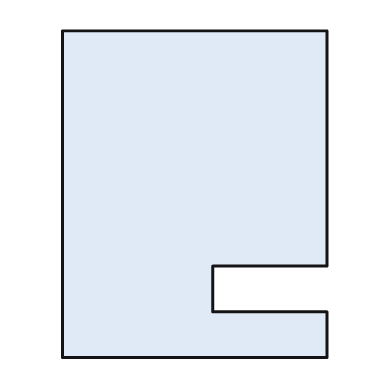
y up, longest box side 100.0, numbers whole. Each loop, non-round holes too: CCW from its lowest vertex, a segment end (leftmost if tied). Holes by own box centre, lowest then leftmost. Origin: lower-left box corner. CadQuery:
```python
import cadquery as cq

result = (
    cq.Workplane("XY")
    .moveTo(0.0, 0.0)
    .lineTo(81.0, 0.0)
    .lineTo(81.0, 14.0)
    .lineTo(46.0, 14.0)
    .lineTo(46.0, 28.0)
    .lineTo(81.0, 28.0)
    .lineTo(81.0, 100.0)
    .lineTo(0.0, 100.0)
    .close()
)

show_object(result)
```